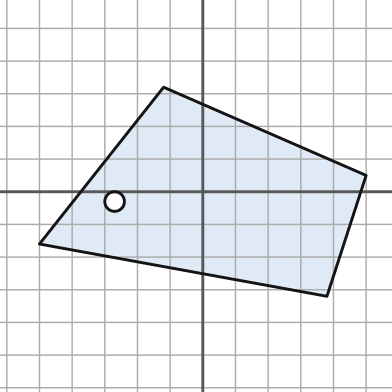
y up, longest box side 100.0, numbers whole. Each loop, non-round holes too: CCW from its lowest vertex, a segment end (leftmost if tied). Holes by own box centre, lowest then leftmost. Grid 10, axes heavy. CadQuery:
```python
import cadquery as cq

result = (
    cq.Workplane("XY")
    .moveTo(38.0, -32.0)
    .lineTo(50.0, 5.0)
    .lineTo(-12.0, 32.0)
    .lineTo(-50.0, -16.0)
    .close()
    .moveTo(-27.0, -3.0)
    .circle(3.0)
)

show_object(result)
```